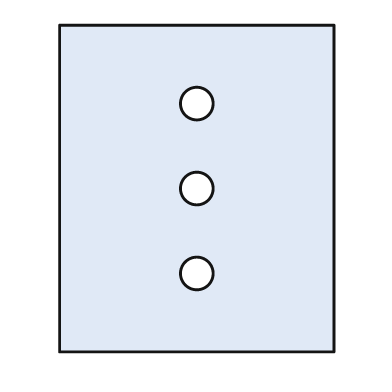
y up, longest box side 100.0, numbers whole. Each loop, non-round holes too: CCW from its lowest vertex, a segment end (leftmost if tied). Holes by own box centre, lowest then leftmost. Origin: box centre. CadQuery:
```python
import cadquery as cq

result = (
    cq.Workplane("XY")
    .moveTo(-42.0, -50.0)
    .lineTo(42.0, -50.0)
    .lineTo(42.0, 50.0)
    .lineTo(-42.0, 50.0)
    .close()
    .moveTo(0.0, -26.0)
    .circle(5.0)
    .moveTo(0.0, 0.0)
    .circle(5.0)
    .moveTo(0.0, 26.0)
    .circle(5.0)
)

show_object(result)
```